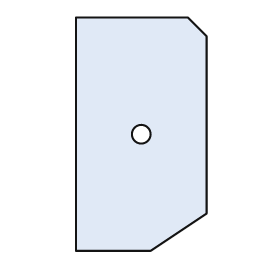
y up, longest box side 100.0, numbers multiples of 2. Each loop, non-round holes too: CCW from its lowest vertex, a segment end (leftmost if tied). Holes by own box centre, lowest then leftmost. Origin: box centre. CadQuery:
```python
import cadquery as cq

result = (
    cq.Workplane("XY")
    .moveTo(-28.0, -50.0)
    .lineTo(4.0, -50.0)
    .lineTo(28.0, -34.0)
    .lineTo(28.0, 42.0)
    .lineTo(20.0, 50.0)
    .lineTo(-28.0, 50.0)
    .close()
    .moveTo(0.0, 0.0)
    .circle(4.0)
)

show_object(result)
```